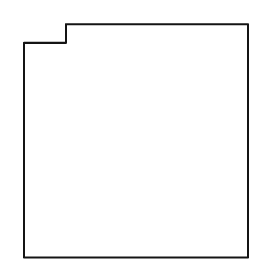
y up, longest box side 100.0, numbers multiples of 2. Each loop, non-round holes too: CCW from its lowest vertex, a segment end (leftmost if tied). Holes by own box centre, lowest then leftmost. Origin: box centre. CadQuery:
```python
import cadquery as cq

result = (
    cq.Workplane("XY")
    .moveTo(-48.0, -50.0)
    .lineTo(48.0, -50.0)
    .lineTo(48.0, 50.0)
    .lineTo(-30.0, 50.0)
    .lineTo(-30.0, 42.0)
    .lineTo(-48.0, 42.0)
    .close()
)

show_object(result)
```